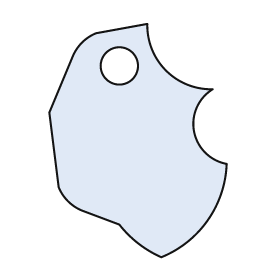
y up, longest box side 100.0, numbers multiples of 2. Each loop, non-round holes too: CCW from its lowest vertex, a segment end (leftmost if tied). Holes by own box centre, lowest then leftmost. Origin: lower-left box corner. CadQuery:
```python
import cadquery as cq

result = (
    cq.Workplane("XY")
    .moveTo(48.0, 0.0)
    .threePointArc((68.0, 16.0), (76.0, 40.0))
    .threePointArc((62.0, 54.0), (70.0, 72.0))
    .threePointArc((50.0, 80.0), (42.0, 100.0))
    .lineTo(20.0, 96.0)
    .threePointArc((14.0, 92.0), (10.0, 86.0))
    .lineTo(0.0, 62.0)
    .lineTo(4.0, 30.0)
    .threePointArc((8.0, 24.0), (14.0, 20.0))
    .lineTo(30.0, 14.0)
    .threePointArc((38.0, 6.0), (48.0, 0.0))
    .close()
    .moveTo(30.0, 82.0)
    .circle(8.0)
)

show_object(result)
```